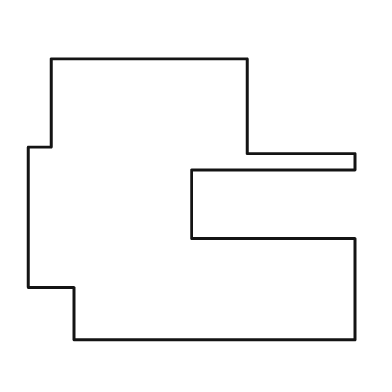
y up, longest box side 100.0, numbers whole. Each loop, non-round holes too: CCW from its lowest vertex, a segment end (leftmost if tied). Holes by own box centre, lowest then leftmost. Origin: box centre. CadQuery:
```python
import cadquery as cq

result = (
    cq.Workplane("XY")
    .moveTo(-36.0, -43.0)
    .lineTo(50.0, -43.0)
    .lineTo(50.0, -12.0)
    .lineTo(0.0, -12.0)
    .lineTo(0.0, 9.0)
    .lineTo(50.0, 9.0)
    .lineTo(50.0, 14.0)
    .lineTo(17.0, 14.0)
    .lineTo(17.0, 43.0)
    .lineTo(-43.0, 43.0)
    .lineTo(-43.0, 16.0)
    .lineTo(-50.0, 16.0)
    .lineTo(-50.0, -27.0)
    .lineTo(-36.0, -27.0)
    .close()
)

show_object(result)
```